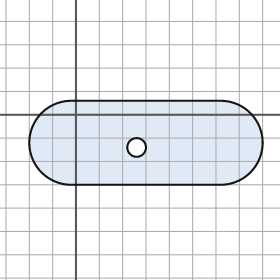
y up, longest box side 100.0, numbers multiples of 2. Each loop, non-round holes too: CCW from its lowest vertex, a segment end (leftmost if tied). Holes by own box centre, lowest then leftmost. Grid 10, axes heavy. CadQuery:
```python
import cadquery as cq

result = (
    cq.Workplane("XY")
    .moveTo(-2.0, -30.0)
    .lineTo(62.0, -30.0)
    .threePointArc((80.0, -12.0), (62.0, 6.0))
    .lineTo(-2.0, 6.0)
    .threePointArc((-20.0, -12.0), (-2.0, -30.0))
    .close()
    .moveTo(26.0, -14.0)
    .circle(4.0)
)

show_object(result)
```